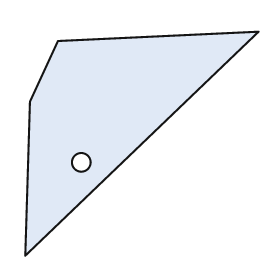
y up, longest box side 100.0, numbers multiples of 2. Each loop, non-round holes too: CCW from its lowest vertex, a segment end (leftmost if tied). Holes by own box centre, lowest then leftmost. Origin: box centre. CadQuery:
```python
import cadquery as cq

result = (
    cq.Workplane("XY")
    .moveTo(-50.0, -48.0)
    .lineTo(50.0, 48.0)
    .lineTo(-36.0, 44.0)
    .lineTo(-48.0, 18.0)
    .close()
    .moveTo(-26.0, -8.0)
    .circle(4.0)
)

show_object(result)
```